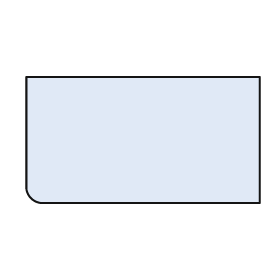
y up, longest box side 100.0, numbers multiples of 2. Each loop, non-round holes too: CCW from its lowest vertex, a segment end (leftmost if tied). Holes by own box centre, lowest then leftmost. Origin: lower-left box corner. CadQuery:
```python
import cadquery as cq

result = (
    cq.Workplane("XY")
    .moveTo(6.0, 0.0)
    .lineTo(100.0, 0.0)
    .lineTo(100.0, 54.0)
    .lineTo(0.0, 54.0)
    .lineTo(0.0, 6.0)
    .threePointArc((2.0, 2.0), (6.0, 0.0))
    .close()
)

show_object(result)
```